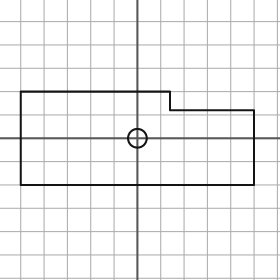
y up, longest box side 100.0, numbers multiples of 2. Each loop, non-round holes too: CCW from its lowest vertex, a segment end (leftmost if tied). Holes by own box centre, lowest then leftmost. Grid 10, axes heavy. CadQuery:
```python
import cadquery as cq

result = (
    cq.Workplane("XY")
    .moveTo(-50.0, -20.0)
    .lineTo(50.0, -20.0)
    .lineTo(50.0, 12.0)
    .lineTo(14.0, 12.0)
    .lineTo(14.0, 20.0)
    .lineTo(-50.0, 20.0)
    .close()
    .moveTo(0.0, 0.0)
    .circle(4.0)
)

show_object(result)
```